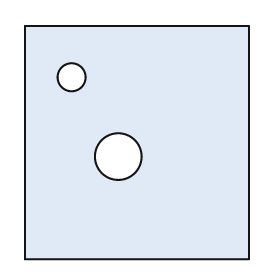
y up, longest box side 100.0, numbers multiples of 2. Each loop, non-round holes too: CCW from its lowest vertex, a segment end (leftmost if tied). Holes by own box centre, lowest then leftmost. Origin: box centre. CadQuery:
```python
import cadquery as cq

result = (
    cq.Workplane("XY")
    .moveTo(-48.0, -50.0)
    .lineTo(48.0, -50.0)
    .lineTo(48.0, 50.0)
    .lineTo(-48.0, 50.0)
    .close()
    .moveTo(-8.0, -6.0)
    .circle(10.0)
    .moveTo(-28.0, 28.0)
    .circle(6.0)
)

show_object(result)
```